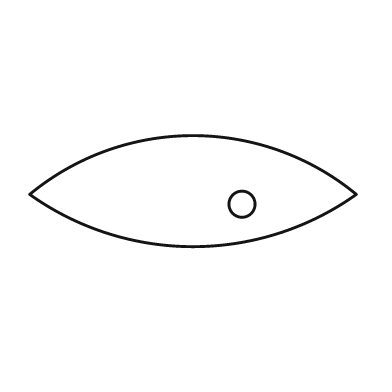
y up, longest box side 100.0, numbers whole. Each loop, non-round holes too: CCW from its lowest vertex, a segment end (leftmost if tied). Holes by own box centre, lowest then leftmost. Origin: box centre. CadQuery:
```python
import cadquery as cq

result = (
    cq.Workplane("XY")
    .moveTo(-50.0, -1.0)
    .threePointArc((0.0, -17.0), (50.0, -1.0))
    .threePointArc((0.0, 17.0), (-50.0, -1.0))
    .close()
    .moveTo(15.0, -4.0)
    .circle(4.0)
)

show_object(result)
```